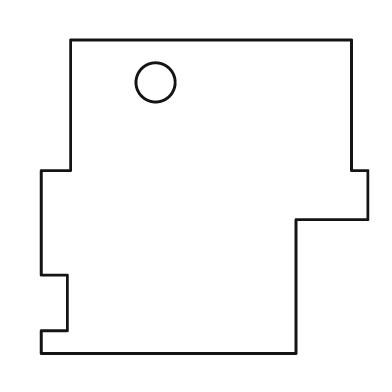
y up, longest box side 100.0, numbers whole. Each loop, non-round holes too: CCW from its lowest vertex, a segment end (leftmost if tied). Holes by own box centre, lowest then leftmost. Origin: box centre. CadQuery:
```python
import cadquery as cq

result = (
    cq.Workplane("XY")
    .moveTo(-50.0, -48.0)
    .lineTo(28.0, -48.0)
    .lineTo(28.0, -7.0)
    .lineTo(50.0, -7.0)
    .lineTo(50.0, 8.0)
    .lineTo(45.0, 8.0)
    .lineTo(45.0, 48.0)
    .lineTo(-41.0, 48.0)
    .lineTo(-41.0, 8.0)
    .lineTo(-50.0, 8.0)
    .lineTo(-50.0, -24.0)
    .lineTo(-42.0, -24.0)
    .lineTo(-42.0, -41.0)
    .lineTo(-50.0, -41.0)
    .close()
    .moveTo(-15.0, 35.0)
    .circle(6.0)
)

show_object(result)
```